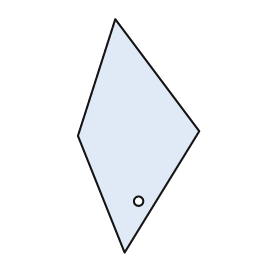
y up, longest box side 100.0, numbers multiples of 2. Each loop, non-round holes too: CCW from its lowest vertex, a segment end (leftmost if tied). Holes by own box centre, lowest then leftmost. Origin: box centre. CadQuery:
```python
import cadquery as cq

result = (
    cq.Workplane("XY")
    .moveTo(-6.0, -50.0)
    .lineTo(26.0, 2.0)
    .lineTo(-10.0, 50.0)
    .lineTo(-26.0, 0.0)
    .close()
    .moveTo(0.0, -28.0)
    .circle(2.0)
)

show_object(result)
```